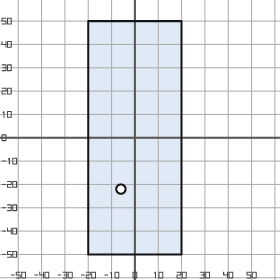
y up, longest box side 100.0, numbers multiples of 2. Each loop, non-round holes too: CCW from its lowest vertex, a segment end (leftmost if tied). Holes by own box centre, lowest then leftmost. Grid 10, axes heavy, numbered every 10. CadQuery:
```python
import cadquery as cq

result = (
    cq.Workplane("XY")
    .moveTo(-20.0, -50.0)
    .lineTo(20.0, -50.0)
    .lineTo(20.0, 50.0)
    .lineTo(-20.0, 50.0)
    .close()
    .moveTo(-6.0, -22.0)
    .circle(2.0)
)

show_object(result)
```